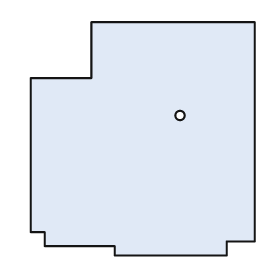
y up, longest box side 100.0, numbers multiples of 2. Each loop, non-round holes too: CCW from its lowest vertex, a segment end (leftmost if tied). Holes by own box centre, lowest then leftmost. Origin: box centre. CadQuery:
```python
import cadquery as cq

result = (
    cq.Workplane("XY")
    .moveTo(-12.0, -50.0)
    .lineTo(36.0, -50.0)
    .lineTo(36.0, -44.0)
    .lineTo(48.0, -44.0)
    .lineTo(48.0, 50.0)
    .lineTo(-22.0, 50.0)
    .lineTo(-22.0, 26.0)
    .lineTo(-48.0, 26.0)
    .lineTo(-48.0, -40.0)
    .lineTo(-42.0, -40.0)
    .lineTo(-42.0, -46.0)
    .lineTo(-12.0, -46.0)
    .close()
    .moveTo(16.0, 10.0)
    .circle(2.0)
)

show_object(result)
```